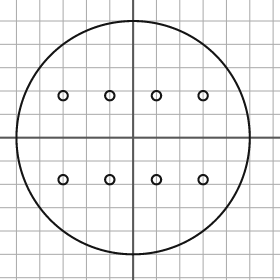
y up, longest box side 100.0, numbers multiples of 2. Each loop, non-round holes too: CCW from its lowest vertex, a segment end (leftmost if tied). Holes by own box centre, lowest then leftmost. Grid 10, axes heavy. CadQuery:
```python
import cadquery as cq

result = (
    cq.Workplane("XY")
    .moveTo(0.0, 0.0)
    .circle(50.0)
    .moveTo(-30.0, -18.0)
    .circle(2.0)
    .moveTo(-10.0, -18.0)
    .circle(2.0)
    .moveTo(10.0, -18.0)
    .circle(2.0)
    .moveTo(30.0, -18.0)
    .circle(2.0)
    .moveTo(-30.0, 18.0)
    .circle(2.0)
    .moveTo(-10.0, 18.0)
    .circle(2.0)
    .moveTo(10.0, 18.0)
    .circle(2.0)
    .moveTo(30.0, 18.0)
    .circle(2.0)
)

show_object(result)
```